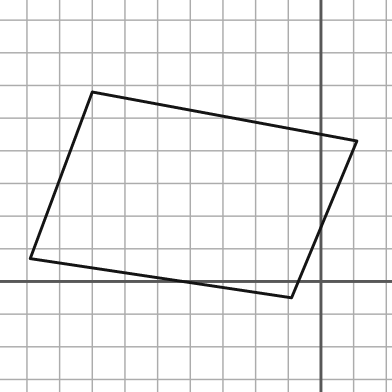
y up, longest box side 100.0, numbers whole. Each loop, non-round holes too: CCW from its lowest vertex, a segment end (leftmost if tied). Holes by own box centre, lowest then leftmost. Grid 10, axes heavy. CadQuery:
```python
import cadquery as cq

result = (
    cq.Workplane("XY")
    .moveTo(-9.0, -5.0)
    .lineTo(11.0, 43.0)
    .lineTo(-70.0, 58.0)
    .lineTo(-89.0, 7.0)
    .close()
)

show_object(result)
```